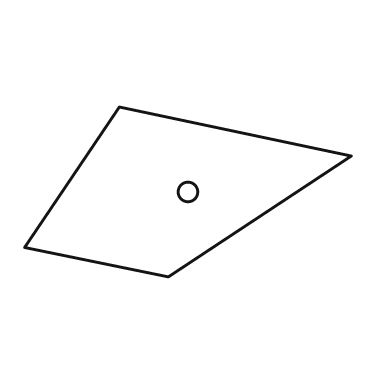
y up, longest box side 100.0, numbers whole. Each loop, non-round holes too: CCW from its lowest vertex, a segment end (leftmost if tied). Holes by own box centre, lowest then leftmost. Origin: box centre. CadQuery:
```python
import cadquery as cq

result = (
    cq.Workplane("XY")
    .moveTo(-6.0, -26.0)
    .lineTo(50.0, 11.0)
    .lineTo(-21.0, 26.0)
    .lineTo(-50.0, -17.0)
    .close()
    .moveTo(0.0, 0.0)
    .circle(3.0)
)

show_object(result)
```